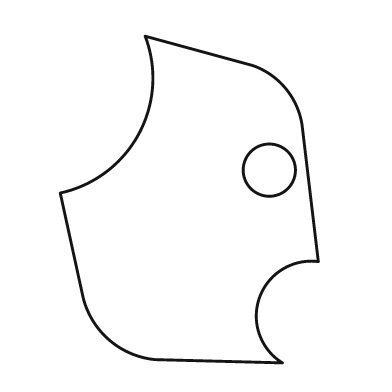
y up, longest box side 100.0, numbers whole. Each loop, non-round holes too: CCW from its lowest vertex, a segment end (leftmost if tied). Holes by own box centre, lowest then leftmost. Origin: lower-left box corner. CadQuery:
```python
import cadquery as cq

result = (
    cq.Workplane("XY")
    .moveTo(68.0, 0.0)
    .threePointArc((61.0, 20.0), (79.0, 31.0))
    .lineTo(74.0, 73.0)
    .threePointArc((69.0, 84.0), (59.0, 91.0))
    .lineTo(26.0, 100.0)
    .threePointArc((24.0, 70.0), (0.0, 52.0))
    .lineTo(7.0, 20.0)
    .threePointArc((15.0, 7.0), (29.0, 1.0))
    .close()
    .moveTo(64.0, 59.0)
    .circle(8.0)
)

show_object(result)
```